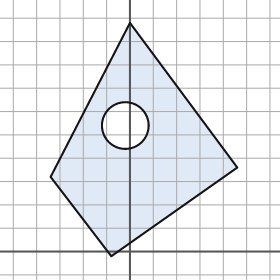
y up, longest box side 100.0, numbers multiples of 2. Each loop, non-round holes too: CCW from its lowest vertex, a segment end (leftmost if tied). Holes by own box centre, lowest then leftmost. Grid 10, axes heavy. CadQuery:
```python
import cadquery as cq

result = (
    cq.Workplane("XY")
    .moveTo(-8.0, -2.0)
    .lineTo(46.0, 36.0)
    .lineTo(0.0, 98.0)
    .lineTo(-34.0, 32.0)
    .close()
    .moveTo(-2.0, 54.0)
    .circle(10.0)
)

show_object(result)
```